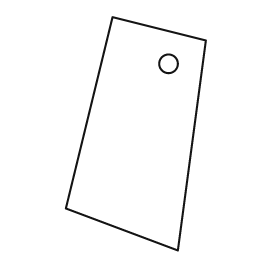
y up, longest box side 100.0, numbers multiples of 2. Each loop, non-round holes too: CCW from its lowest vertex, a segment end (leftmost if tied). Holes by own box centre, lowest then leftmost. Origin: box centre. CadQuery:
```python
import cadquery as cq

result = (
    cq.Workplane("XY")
    .moveTo(18.0, -50.0)
    .lineTo(30.0, 40.0)
    .lineTo(-10.0, 50.0)
    .lineTo(-30.0, -32.0)
    .close()
    .moveTo(14.0, 30.0)
    .circle(4.0)
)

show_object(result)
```